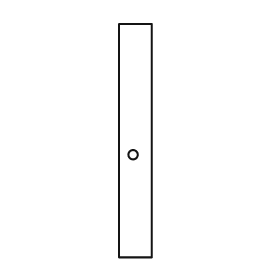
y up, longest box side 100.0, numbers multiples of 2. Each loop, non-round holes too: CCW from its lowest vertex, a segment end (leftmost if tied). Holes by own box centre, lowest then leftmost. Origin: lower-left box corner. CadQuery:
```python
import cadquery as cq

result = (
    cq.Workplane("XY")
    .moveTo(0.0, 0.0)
    .lineTo(14.0, 0.0)
    .lineTo(14.0, 100.0)
    .lineTo(0.0, 100.0)
    .close()
    .moveTo(6.0, 44.0)
    .circle(2.0)
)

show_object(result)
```